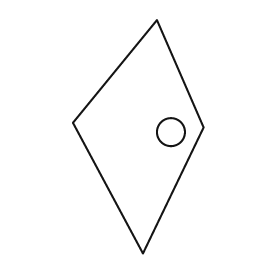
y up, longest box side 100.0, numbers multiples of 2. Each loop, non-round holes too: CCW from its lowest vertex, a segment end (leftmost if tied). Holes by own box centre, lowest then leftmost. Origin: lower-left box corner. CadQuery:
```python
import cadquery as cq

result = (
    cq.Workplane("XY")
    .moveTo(30.0, 0.0)
    .lineTo(56.0, 54.0)
    .lineTo(36.0, 100.0)
    .lineTo(0.0, 56.0)
    .close()
    .moveTo(42.0, 52.0)
    .circle(6.0)
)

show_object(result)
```